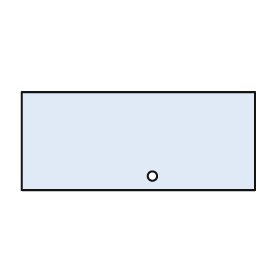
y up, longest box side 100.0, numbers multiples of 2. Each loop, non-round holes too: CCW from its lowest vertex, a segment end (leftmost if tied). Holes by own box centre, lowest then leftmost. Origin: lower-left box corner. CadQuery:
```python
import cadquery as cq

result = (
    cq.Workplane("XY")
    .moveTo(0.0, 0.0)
    .lineTo(100.0, 0.0)
    .lineTo(100.0, 42.0)
    .lineTo(0.0, 42.0)
    .close()
    .moveTo(56.0, 6.0)
    .circle(2.0)
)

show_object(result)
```